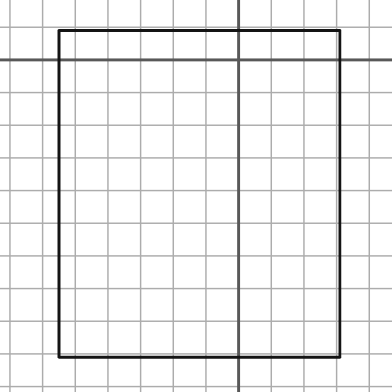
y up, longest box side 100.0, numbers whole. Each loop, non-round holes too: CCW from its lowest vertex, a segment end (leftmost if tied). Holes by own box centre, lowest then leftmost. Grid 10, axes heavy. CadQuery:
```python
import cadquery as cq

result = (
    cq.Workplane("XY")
    .moveTo(-55.0, -91.0)
    .lineTo(31.0, -91.0)
    .lineTo(31.0, 9.0)
    .lineTo(-55.0, 9.0)
    .close()
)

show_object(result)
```